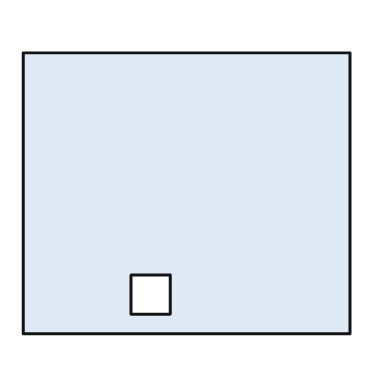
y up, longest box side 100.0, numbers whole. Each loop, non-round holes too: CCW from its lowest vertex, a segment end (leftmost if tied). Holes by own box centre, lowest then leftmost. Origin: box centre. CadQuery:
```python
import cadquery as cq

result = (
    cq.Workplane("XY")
    .moveTo(-50.0, -43.0)
    .lineTo(50.0, -43.0)
    .lineTo(50.0, 43.0)
    .lineTo(-50.0, 43.0)
    .close()
    .moveTo(-17.0, -37.0)
    .lineTo(-5.0, -37.0)
    .lineTo(-5.0, -25.0)
    .lineTo(-17.0, -25.0)
    .close()
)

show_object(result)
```